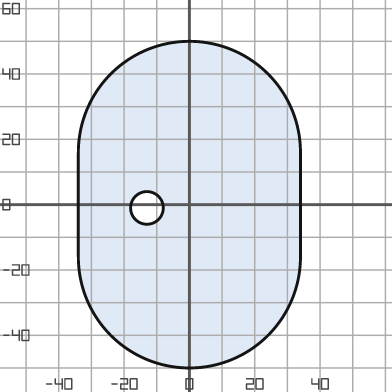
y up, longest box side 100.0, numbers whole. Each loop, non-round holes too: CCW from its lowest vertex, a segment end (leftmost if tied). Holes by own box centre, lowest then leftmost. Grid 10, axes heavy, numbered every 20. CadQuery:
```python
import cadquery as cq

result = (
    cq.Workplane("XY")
    .moveTo(-34.0, -16.0)
    .threePointArc((0.0, -50.0), (34.0, -16.0))
    .lineTo(34.0, 16.0)
    .threePointArc((0.0, 50.0), (-34.0, 16.0))
    .close()
    .moveTo(-13.0, -1.0)
    .circle(5.0)
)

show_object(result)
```